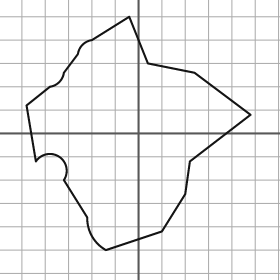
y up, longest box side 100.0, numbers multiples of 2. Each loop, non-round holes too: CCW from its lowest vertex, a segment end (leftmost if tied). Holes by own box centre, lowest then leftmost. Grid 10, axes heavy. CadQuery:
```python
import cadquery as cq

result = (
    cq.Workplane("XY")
    .moveTo(-14.0, -50.0)
    .lineTo(10.0, -42.0)
    .lineTo(20.0, -26.0)
    .lineTo(22.0, -12.0)
    .lineTo(48.0, 8.0)
    .lineTo(24.0, 26.0)
    .lineTo(4.0, 30.0)
    .lineTo(-4.0, 50.0)
    .lineTo(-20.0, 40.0)
    .threePointArc((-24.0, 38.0), (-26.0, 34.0))
    .lineTo(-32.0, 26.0)
    .threePointArc((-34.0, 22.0), (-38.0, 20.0))
    .lineTo(-48.0, 12.0)
    .lineTo(-44.0, -12.0)
    .threePointArc((-34.0, -10.0), (-32.0, -20.0))
    .lineTo(-22.0, -36.0)
    .threePointArc((-20.0, -44.0), (-14.0, -50.0))
    .close()
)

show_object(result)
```